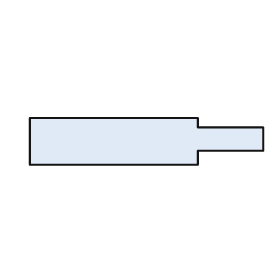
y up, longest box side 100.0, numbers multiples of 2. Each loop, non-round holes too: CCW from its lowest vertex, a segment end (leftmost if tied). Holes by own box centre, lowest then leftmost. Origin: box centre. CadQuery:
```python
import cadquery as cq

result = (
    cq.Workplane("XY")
    .moveTo(-50.0, -10.0)
    .lineTo(22.0, -10.0)
    .lineTo(22.0, -4.0)
    .lineTo(50.0, -4.0)
    .lineTo(50.0, 6.0)
    .lineTo(22.0, 6.0)
    .lineTo(22.0, 10.0)
    .lineTo(-50.0, 10.0)
    .close()
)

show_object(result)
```